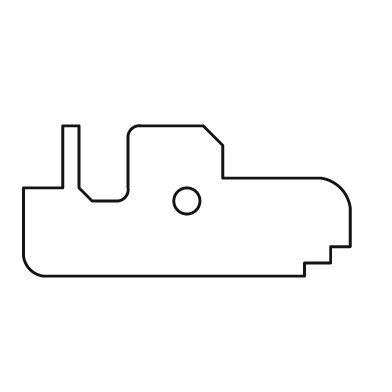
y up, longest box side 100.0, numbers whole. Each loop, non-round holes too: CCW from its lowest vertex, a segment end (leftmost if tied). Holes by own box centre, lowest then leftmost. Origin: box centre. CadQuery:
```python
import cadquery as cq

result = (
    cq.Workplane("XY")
    .moveTo(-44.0, -23.0)
    .lineTo(36.0, -23.0)
    .lineTo(36.0, -19.0)
    .lineTo(44.0, -19.0)
    .lineTo(44.0, -14.0)
    .lineTo(50.0, -14.0)
    .lineTo(50.0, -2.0)
    .threePointArc((47.0, 4.0), (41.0, 7.0))
    .lineTo(11.0, 7.0)
    .lineTo(11.0, 17.0)
    .lineTo(5.0, 23.0)
    .lineTo(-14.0, 23.0)
    .threePointArc((-17.0, 22.0), (-18.0, 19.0))
    .lineTo(-18.0, 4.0)
    .threePointArc((-19.0, 1.0), (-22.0, 0.0))
    .lineTo(-29.0, 0.0)
    .lineTo(-33.0, 4.0)
    .lineTo(-33.0, 23.0)
    .lineTo(-38.0, 23.0)
    .lineTo(-38.0, 4.0)
    .lineTo(-50.0, 4.0)
    .lineTo(-50.0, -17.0)
    .threePointArc((-48.0, -21.0), (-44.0, -23.0))
    .close()
    .moveTo(0.0, 0.0)
    .circle(4.0)
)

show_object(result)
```